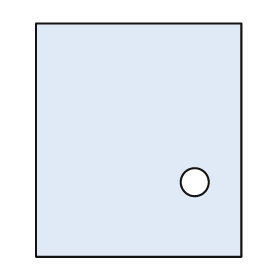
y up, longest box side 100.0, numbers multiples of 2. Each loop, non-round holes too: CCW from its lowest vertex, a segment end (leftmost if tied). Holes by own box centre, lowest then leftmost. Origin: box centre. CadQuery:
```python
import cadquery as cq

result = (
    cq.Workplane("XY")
    .moveTo(-44.0, -50.0)
    .lineTo(44.0, -50.0)
    .lineTo(44.0, 50.0)
    .lineTo(-44.0, 50.0)
    .close()
    .moveTo(24.0, -18.0)
    .circle(6.0)
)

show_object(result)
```